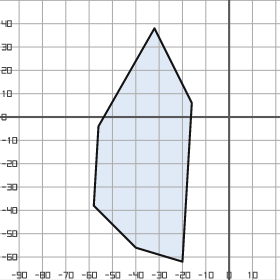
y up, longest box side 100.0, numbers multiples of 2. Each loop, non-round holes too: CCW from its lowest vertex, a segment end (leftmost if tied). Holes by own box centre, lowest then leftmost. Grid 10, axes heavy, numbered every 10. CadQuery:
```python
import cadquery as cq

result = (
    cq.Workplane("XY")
    .moveTo(-20.0, -62.0)
    .lineTo(-16.0, 6.0)
    .lineTo(-32.0, 38.0)
    .lineTo(-56.0, -4.0)
    .lineTo(-58.0, -38.0)
    .lineTo(-40.0, -56.0)
    .close()
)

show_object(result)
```